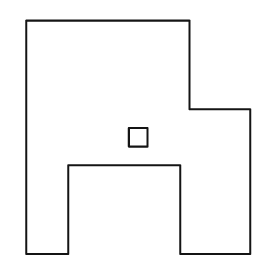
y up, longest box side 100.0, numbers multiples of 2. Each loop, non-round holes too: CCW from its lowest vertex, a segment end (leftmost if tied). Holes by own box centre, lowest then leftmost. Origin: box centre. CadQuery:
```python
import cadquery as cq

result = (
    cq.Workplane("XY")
    .moveTo(-48.0, -50.0)
    .lineTo(-30.0, -50.0)
    .lineTo(-30.0, -12.0)
    .lineTo(18.0, -12.0)
    .lineTo(18.0, -50.0)
    .lineTo(48.0, -50.0)
    .lineTo(48.0, 12.0)
    .lineTo(22.0, 12.0)
    .lineTo(22.0, 50.0)
    .lineTo(-48.0, 50.0)
    .close()
    .moveTo(-4.0, -4.0)
    .lineTo(4.0, -4.0)
    .lineTo(4.0, 4.0)
    .lineTo(-4.0, 4.0)
    .close()
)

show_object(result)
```